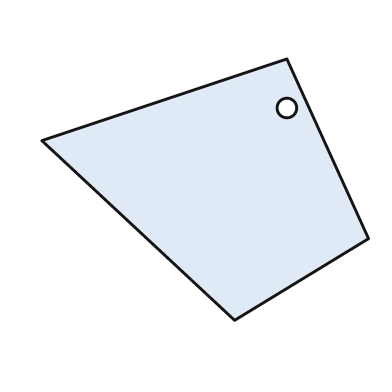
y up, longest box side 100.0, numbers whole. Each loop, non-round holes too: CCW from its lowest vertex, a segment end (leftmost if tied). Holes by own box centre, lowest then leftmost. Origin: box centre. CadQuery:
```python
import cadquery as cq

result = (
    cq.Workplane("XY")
    .moveTo(9.0, -40.0)
    .lineTo(50.0, -15.0)
    .lineTo(25.0, 40.0)
    .lineTo(-50.0, 15.0)
    .close()
    .moveTo(25.0, 25.0)
    .circle(3.0)
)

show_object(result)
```